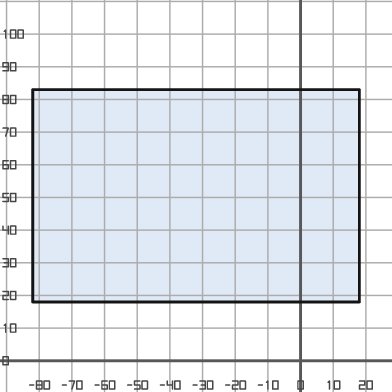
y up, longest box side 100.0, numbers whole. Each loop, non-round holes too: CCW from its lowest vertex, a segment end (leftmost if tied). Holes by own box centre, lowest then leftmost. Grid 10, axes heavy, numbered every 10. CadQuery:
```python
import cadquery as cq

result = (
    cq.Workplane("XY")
    .moveTo(-82.0, 18.0)
    .lineTo(18.0, 18.0)
    .lineTo(18.0, 83.0)
    .lineTo(-82.0, 83.0)
    .close()
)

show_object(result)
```